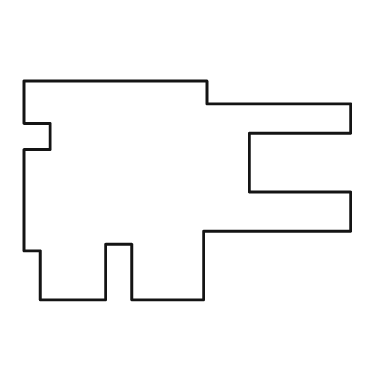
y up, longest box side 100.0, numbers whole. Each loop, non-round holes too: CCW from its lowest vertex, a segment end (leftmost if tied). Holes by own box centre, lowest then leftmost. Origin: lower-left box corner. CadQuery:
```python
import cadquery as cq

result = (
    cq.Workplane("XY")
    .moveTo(5.0, 0.0)
    .lineTo(25.0, 0.0)
    .lineTo(25.0, 17.0)
    .lineTo(33.0, 17.0)
    .lineTo(33.0, 0.0)
    .lineTo(55.0, 0.0)
    .lineTo(55.0, 21.0)
    .lineTo(100.0, 21.0)
    .lineTo(100.0, 33.0)
    .lineTo(69.0, 33.0)
    .lineTo(69.0, 51.0)
    .lineTo(100.0, 51.0)
    .lineTo(100.0, 60.0)
    .lineTo(56.0, 60.0)
    .lineTo(56.0, 67.0)
    .lineTo(0.0, 67.0)
    .lineTo(0.0, 54.0)
    .lineTo(8.0, 54.0)
    .lineTo(8.0, 46.0)
    .lineTo(0.0, 46.0)
    .lineTo(0.0, 15.0)
    .lineTo(5.0, 15.0)
    .close()
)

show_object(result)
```